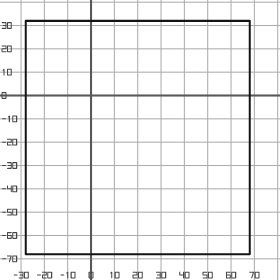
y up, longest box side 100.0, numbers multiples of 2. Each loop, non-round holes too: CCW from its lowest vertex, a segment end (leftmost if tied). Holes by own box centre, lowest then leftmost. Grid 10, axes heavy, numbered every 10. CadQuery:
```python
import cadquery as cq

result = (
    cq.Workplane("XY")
    .moveTo(-28.0, -68.0)
    .lineTo(68.0, -68.0)
    .lineTo(68.0, 32.0)
    .lineTo(-28.0, 32.0)
    .close()
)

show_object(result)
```